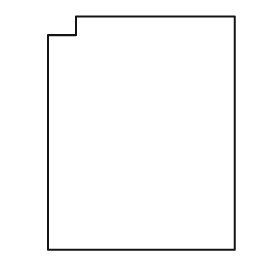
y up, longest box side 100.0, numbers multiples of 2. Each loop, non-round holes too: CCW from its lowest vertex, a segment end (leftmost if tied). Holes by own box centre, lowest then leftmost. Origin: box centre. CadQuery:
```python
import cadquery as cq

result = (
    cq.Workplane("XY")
    .moveTo(-40.0, -50.0)
    .lineTo(40.0, -50.0)
    .lineTo(40.0, 50.0)
    .lineTo(-28.0, 50.0)
    .lineTo(-28.0, 42.0)
    .lineTo(-40.0, 42.0)
    .close()
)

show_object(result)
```